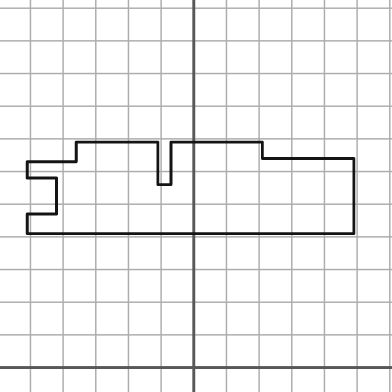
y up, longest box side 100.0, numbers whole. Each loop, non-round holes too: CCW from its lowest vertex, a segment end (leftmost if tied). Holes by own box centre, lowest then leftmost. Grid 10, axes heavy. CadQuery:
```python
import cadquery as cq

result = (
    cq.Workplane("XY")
    .moveTo(-51.0, 41.0)
    .lineTo(49.0, 41.0)
    .lineTo(49.0, 64.0)
    .lineTo(21.0, 64.0)
    .lineTo(21.0, 69.0)
    .lineTo(-7.0, 69.0)
    .lineTo(-7.0, 56.0)
    .lineTo(-11.0, 56.0)
    .lineTo(-11.0, 69.0)
    .lineTo(-36.0, 69.0)
    .lineTo(-36.0, 63.0)
    .lineTo(-51.0, 63.0)
    .lineTo(-51.0, 58.0)
    .lineTo(-42.0, 58.0)
    .lineTo(-42.0, 47.0)
    .lineTo(-51.0, 47.0)
    .close()
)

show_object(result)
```